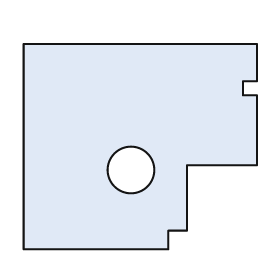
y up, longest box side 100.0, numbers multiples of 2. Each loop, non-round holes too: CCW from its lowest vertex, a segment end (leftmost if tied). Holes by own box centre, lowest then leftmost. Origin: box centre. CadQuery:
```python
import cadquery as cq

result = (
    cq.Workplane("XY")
    .moveTo(-50.0, -44.0)
    .lineTo(12.0, -44.0)
    .lineTo(12.0, -36.0)
    .lineTo(20.0, -36.0)
    .lineTo(20.0, -8.0)
    .lineTo(50.0, -8.0)
    .lineTo(50.0, 22.0)
    .lineTo(44.0, 22.0)
    .lineTo(44.0, 28.0)
    .lineTo(50.0, 28.0)
    .lineTo(50.0, 44.0)
    .lineTo(-50.0, 44.0)
    .close()
    .moveTo(-4.0, -10.0)
    .circle(10.0)
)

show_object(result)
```